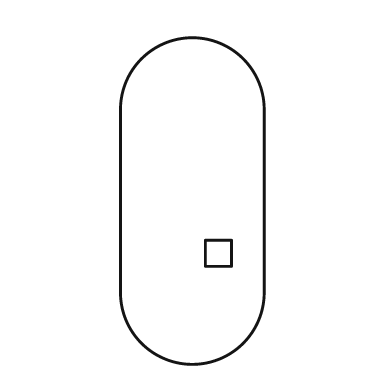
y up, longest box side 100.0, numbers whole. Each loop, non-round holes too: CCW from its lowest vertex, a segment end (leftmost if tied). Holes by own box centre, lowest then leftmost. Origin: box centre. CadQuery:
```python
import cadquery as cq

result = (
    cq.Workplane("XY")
    .moveTo(-22.0, -28.0)
    .threePointArc((0.0, -50.0), (22.0, -28.0))
    .lineTo(22.0, 28.0)
    .threePointArc((0.0, 50.0), (-22.0, 28.0))
    .close()
    .moveTo(4.0, -20.0)
    .lineTo(12.0, -20.0)
    .lineTo(12.0, -12.0)
    .lineTo(4.0, -12.0)
    .close()
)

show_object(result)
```